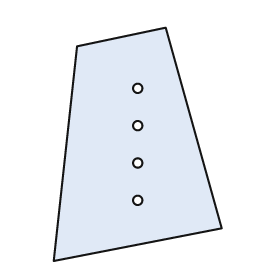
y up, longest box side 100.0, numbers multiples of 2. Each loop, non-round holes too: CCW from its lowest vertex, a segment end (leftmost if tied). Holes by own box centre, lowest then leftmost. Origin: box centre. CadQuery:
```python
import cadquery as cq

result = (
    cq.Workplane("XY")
    .moveTo(-36.0, -50.0)
    .lineTo(36.0, -36.0)
    .lineTo(12.0, 50.0)
    .lineTo(-26.0, 42.0)
    .close()
    .moveTo(0.0, -24.0)
    .circle(2.0)
    .moveTo(0.0, -8.0)
    .circle(2.0)
    .moveTo(0.0, 8.0)
    .circle(2.0)
    .moveTo(0.0, 24.0)
    .circle(2.0)
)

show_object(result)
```